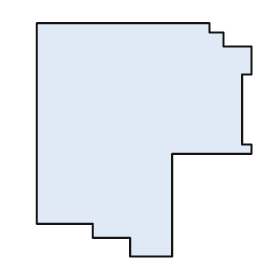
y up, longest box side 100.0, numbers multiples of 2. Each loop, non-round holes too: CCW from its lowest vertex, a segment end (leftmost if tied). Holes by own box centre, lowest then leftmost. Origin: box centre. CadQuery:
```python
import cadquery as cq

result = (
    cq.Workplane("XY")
    .moveTo(-6.0, -50.0)
    .lineTo(12.0, -50.0)
    .lineTo(12.0, -6.0)
    .lineTo(46.0, -6.0)
    .lineTo(46.0, -2.0)
    .lineTo(42.0, -2.0)
    .lineTo(42.0, 28.0)
    .lineTo(46.0, 28.0)
    .lineTo(46.0, 40.0)
    .lineTo(34.0, 40.0)
    .lineTo(34.0, 46.0)
    .lineTo(28.0, 46.0)
    .lineTo(28.0, 50.0)
    .lineTo(-46.0, 50.0)
    .lineTo(-46.0, -36.0)
    .lineTo(-22.0, -36.0)
    .lineTo(-22.0, -42.0)
    .lineTo(-6.0, -42.0)
    .close()
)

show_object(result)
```